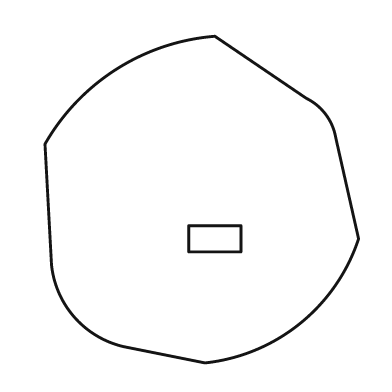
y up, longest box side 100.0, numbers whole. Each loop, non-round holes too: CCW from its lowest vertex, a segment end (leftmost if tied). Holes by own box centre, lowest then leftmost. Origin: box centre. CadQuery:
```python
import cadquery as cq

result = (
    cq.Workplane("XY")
    .moveTo(1.0, -50.0)
    .threePointArc((30.0, -38.0), (48.0, -12.0))
    .lineTo(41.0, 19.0)
    .threePointArc((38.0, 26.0), (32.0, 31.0))
    .lineTo(4.0, 50.0)
    .threePointArc((-26.0, 40.0), (-48.0, 17.0))
    .lineTo(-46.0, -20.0)
    .threePointArc((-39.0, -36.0), (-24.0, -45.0))
    .close()
    .moveTo(-4.0, -16.0)
    .lineTo(12.0, -16.0)
    .lineTo(12.0, -8.0)
    .lineTo(-4.0, -8.0)
    .close()
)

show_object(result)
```